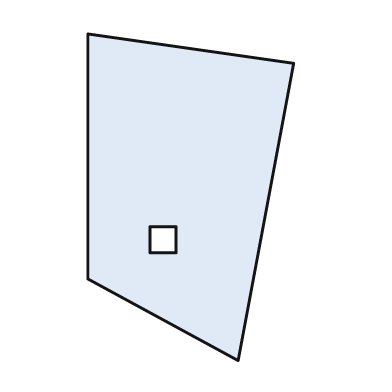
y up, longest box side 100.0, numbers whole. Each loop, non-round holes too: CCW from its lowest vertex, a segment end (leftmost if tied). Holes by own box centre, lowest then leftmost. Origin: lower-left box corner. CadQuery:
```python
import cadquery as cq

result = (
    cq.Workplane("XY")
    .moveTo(46.0, 0.0)
    .lineTo(63.0, 91.0)
    .lineTo(0.0, 100.0)
    .lineTo(0.0, 25.0)
    .close()
    .moveTo(19.0, 33.0)
    .lineTo(27.0, 33.0)
    .lineTo(27.0, 41.0)
    .lineTo(19.0, 41.0)
    .close()
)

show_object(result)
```